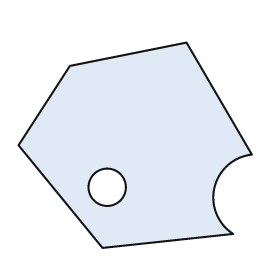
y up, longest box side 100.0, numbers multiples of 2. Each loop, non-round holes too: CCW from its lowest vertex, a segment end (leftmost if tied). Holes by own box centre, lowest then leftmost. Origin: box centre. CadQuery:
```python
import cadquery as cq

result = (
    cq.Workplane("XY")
    .moveTo(-14.0, -44.0)
    .lineTo(42.0, -38.0)
    .threePointArc((34.0, -18.0), (50.0, -4.0))
    .lineTo(22.0, 44.0)
    .lineTo(-28.0, 34.0)
    .lineTo(-50.0, 0.0)
    .close()
    .moveTo(-12.0, -18.0)
    .circle(8.0)
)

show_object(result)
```